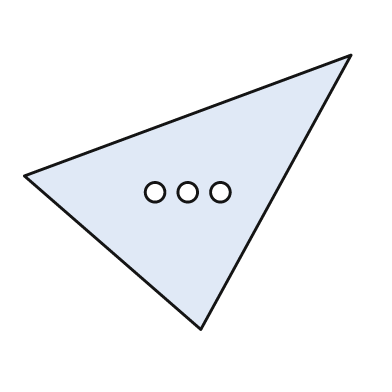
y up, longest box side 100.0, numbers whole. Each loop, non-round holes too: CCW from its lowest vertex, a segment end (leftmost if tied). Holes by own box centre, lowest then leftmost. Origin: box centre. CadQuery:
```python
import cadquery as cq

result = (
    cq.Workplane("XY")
    .moveTo(4.0, -42.0)
    .lineTo(50.0, 42.0)
    .lineTo(-50.0, 5.0)
    .close()
    .moveTo(-10.0, 0.0)
    .circle(3.0)
    .moveTo(0.0, 0.0)
    .circle(3.0)
    .moveTo(10.0, 0.0)
    .circle(3.0)
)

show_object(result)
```